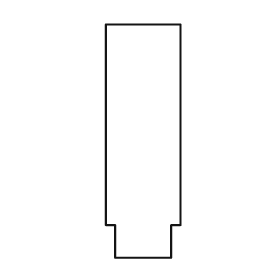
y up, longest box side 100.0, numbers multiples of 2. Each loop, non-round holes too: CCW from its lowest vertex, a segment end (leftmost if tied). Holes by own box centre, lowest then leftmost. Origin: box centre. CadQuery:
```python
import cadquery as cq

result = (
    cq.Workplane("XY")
    .moveTo(-12.0, -50.0)
    .lineTo(12.0, -50.0)
    .lineTo(12.0, -36.0)
    .lineTo(16.0, -36.0)
    .lineTo(16.0, 50.0)
    .lineTo(-16.0, 50.0)
    .lineTo(-16.0, -36.0)
    .lineTo(-12.0, -36.0)
    .close()
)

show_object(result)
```